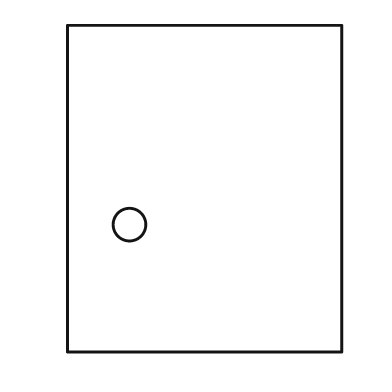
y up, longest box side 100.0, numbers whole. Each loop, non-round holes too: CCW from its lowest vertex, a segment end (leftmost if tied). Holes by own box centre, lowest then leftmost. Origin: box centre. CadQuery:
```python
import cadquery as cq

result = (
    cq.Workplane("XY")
    .moveTo(-42.0, -50.0)
    .lineTo(42.0, -50.0)
    .lineTo(42.0, 50.0)
    .lineTo(-42.0, 50.0)
    .close()
    .moveTo(-23.0, -11.0)
    .circle(5.0)
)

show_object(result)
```